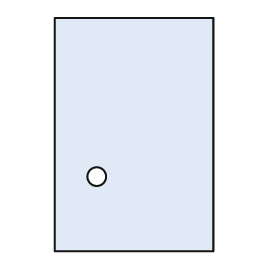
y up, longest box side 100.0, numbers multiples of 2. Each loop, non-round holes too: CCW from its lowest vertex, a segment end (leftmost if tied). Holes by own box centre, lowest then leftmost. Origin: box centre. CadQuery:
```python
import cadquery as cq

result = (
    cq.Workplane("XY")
    .moveTo(-34.0, -50.0)
    .lineTo(34.0, -50.0)
    .lineTo(34.0, 50.0)
    .lineTo(-34.0, 50.0)
    .close()
    .moveTo(-16.0, -18.0)
    .circle(4.0)
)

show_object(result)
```